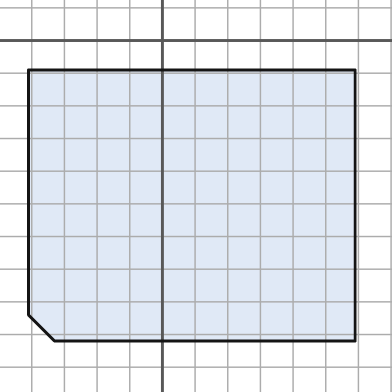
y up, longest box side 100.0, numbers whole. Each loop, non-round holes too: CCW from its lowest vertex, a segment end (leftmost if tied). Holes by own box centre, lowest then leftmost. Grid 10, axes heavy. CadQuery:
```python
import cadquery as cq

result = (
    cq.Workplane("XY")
    .moveTo(-33.0, -92.0)
    .lineTo(59.0, -92.0)
    .lineTo(59.0, -9.0)
    .lineTo(-41.0, -9.0)
    .lineTo(-41.0, -84.0)
    .close()
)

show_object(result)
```